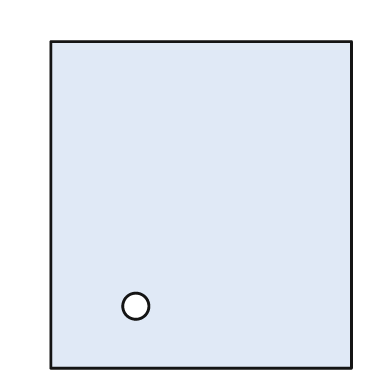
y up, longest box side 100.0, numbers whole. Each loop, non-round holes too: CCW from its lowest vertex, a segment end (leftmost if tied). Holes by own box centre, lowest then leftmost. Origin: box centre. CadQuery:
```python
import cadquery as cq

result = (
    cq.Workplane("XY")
    .moveTo(-46.0, -50.0)
    .lineTo(46.0, -50.0)
    .lineTo(46.0, 50.0)
    .lineTo(-46.0, 50.0)
    .close()
    .moveTo(-20.0, -31.0)
    .circle(4.0)
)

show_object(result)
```